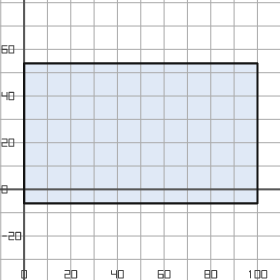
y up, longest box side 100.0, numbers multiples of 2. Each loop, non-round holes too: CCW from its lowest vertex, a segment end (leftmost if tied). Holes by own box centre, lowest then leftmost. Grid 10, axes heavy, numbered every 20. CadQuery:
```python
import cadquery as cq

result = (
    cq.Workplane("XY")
    .moveTo(0.0, -6.0)
    .lineTo(100.0, -6.0)
    .lineTo(100.0, 54.0)
    .lineTo(0.0, 54.0)
    .close()
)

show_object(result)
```